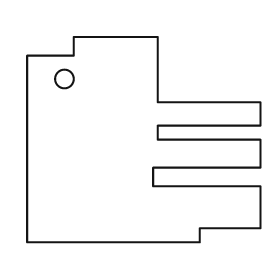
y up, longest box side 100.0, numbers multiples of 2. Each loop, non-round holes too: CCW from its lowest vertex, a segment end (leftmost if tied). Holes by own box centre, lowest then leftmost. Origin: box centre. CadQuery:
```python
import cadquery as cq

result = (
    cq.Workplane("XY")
    .moveTo(-50.0, -44.0)
    .lineTo(24.0, -44.0)
    .lineTo(24.0, -38.0)
    .lineTo(50.0, -38.0)
    .lineTo(50.0, -20.0)
    .lineTo(4.0, -20.0)
    .lineTo(4.0, -12.0)
    .lineTo(50.0, -12.0)
    .lineTo(50.0, 0.0)
    .lineTo(6.0, 0.0)
    .lineTo(6.0, 6.0)
    .lineTo(50.0, 6.0)
    .lineTo(50.0, 16.0)
    .lineTo(6.0, 16.0)
    .lineTo(6.0, 44.0)
    .lineTo(-30.0, 44.0)
    .lineTo(-30.0, 36.0)
    .lineTo(-50.0, 36.0)
    .close()
    .moveTo(-34.0, 26.0)
    .circle(4.0)
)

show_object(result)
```